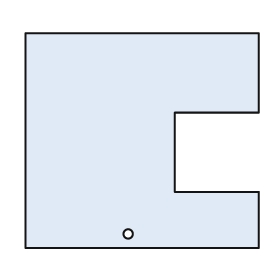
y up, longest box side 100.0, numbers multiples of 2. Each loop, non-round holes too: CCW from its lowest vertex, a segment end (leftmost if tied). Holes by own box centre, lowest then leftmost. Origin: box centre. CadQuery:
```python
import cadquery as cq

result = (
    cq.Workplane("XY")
    .moveTo(-50.0, -46.0)
    .lineTo(50.0, -46.0)
    .lineTo(50.0, -22.0)
    .lineTo(14.0, -22.0)
    .lineTo(14.0, 12.0)
    .lineTo(50.0, 12.0)
    .lineTo(50.0, 46.0)
    .lineTo(-50.0, 46.0)
    .close()
    .moveTo(-6.0, -40.0)
    .circle(2.0)
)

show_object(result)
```